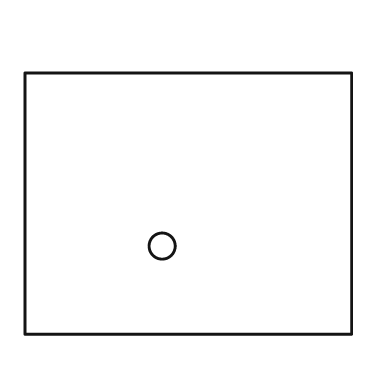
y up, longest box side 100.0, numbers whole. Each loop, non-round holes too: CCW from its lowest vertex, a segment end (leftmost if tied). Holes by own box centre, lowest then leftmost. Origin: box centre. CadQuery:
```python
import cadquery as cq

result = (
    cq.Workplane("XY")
    .moveTo(-50.0, -40.0)
    .lineTo(50.0, -40.0)
    .lineTo(50.0, 40.0)
    .lineTo(-50.0, 40.0)
    .close()
    .moveTo(-8.0, -13.0)
    .circle(4.0)
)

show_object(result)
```